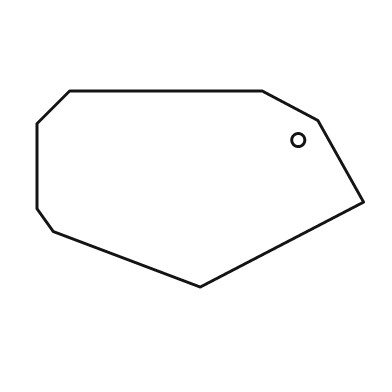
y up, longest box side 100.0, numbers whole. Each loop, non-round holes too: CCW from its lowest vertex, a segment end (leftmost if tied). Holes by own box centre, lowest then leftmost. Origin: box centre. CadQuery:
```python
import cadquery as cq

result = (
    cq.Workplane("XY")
    .moveTo(0.0, -30.0)
    .lineTo(50.0, -4.0)
    .lineTo(36.0, 21.0)
    .lineTo(19.0, 30.0)
    .lineTo(-40.0, 30.0)
    .lineTo(-50.0, 20.0)
    .lineTo(-50.0, -6.0)
    .lineTo(-45.0, -13.0)
    .close()
    .moveTo(30.0, 15.0)
    .circle(2.0)
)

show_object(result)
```